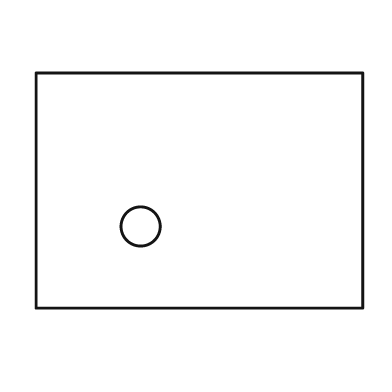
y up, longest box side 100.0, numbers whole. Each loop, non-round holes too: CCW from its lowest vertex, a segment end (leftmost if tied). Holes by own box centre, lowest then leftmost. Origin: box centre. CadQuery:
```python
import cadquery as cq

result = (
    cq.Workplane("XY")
    .moveTo(-50.0, -36.0)
    .lineTo(50.0, -36.0)
    .lineTo(50.0, 36.0)
    .lineTo(-50.0, 36.0)
    .close()
    .moveTo(-18.0, -11.0)
    .circle(6.0)
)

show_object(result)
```